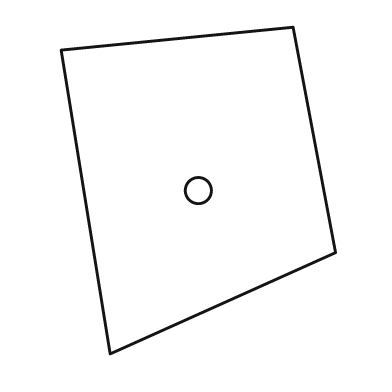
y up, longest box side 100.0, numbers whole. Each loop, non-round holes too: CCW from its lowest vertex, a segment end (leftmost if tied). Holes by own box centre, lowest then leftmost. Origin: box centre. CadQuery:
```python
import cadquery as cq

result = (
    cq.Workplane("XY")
    .moveTo(-27.0, -50.0)
    .lineTo(42.0, -19.0)
    .lineTo(29.0, 50.0)
    .lineTo(-42.0, 43.0)
    .close()
    .moveTo(0.0, 0.0)
    .circle(4.0)
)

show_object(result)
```